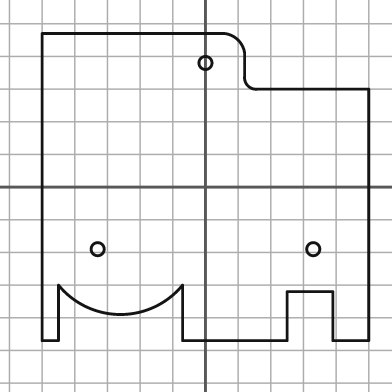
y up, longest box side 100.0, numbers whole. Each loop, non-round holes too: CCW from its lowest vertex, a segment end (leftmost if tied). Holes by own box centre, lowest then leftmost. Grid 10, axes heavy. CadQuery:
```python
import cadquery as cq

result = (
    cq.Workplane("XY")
    .moveTo(-50.0, -47.0)
    .lineTo(-45.0, -47.0)
    .lineTo(-45.0, -30.0)
    .threePointArc((-26.0, -39.0), (-7.0, -30.0))
    .lineTo(-7.0, -47.0)
    .lineTo(25.0, -47.0)
    .lineTo(25.0, -32.0)
    .lineTo(39.0, -32.0)
    .lineTo(39.0, -47.0)
    .lineTo(50.0, -47.0)
    .lineTo(50.0, 30.0)
    .lineTo(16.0, 30.0)
    .threePointArc((13.0, 31.0), (12.0, 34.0))
    .lineTo(12.0, 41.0)
    .threePointArc((10.0, 45.0), (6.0, 47.0))
    .lineTo(-50.0, 47.0)
    .close()
    .moveTo(-33.0, -19.0)
    .circle(2.0)
    .moveTo(33.0, -19.0)
    .circle(2.0)
    .moveTo(0.0, 38.0)
    .circle(2.0)
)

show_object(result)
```